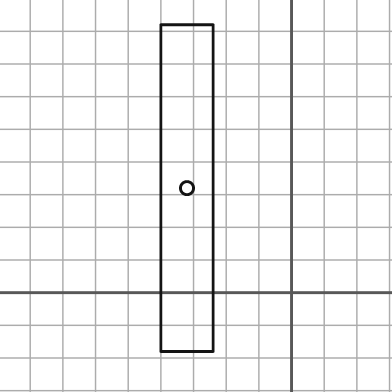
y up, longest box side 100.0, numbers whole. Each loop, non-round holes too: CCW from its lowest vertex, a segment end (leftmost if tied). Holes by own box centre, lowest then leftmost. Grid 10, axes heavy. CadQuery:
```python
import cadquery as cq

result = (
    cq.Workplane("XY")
    .moveTo(-40.0, -18.0)
    .lineTo(-24.0, -18.0)
    .lineTo(-24.0, 82.0)
    .lineTo(-40.0, 82.0)
    .close()
    .moveTo(-32.0, 32.0)
    .circle(2.0)
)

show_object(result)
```